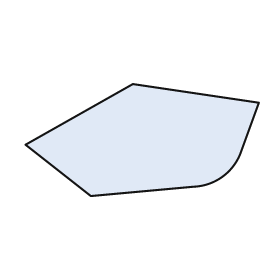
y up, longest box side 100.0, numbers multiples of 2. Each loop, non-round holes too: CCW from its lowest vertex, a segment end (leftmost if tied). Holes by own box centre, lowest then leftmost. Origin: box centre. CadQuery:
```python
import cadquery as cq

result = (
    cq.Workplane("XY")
    .moveTo(-22.0, -24.0)
    .lineTo(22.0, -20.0)
    .threePointArc((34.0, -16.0), (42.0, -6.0))
    .lineTo(50.0, 16.0)
    .lineTo(-4.0, 24.0)
    .lineTo(-50.0, -2.0)
    .close()
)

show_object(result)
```